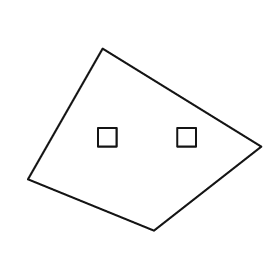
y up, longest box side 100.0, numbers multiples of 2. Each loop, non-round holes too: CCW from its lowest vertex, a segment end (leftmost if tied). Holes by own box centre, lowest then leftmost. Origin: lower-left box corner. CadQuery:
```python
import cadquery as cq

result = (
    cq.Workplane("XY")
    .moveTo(54.0, 0.0)
    .lineTo(100.0, 36.0)
    .lineTo(32.0, 78.0)
    .lineTo(0.0, 22.0)
    .close()
    .moveTo(30.0, 36.0)
    .lineTo(38.0, 36.0)
    .lineTo(38.0, 44.0)
    .lineTo(30.0, 44.0)
    .close()
    .moveTo(64.0, 36.0)
    .lineTo(72.0, 36.0)
    .lineTo(72.0, 44.0)
    .lineTo(64.0, 44.0)
    .close()
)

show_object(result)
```